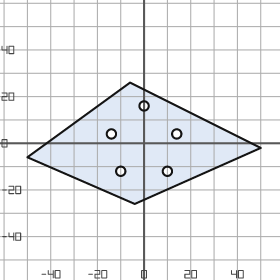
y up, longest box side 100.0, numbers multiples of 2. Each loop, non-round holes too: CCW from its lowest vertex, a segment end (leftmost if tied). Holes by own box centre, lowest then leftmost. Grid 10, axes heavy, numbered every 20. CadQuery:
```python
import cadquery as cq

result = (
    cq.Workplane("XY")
    .moveTo(-4.0, -26.0)
    .lineTo(50.0, -2.0)
    .lineTo(-6.0, 26.0)
    .lineTo(-50.0, -6.0)
    .close()
    .moveTo(-10.0, -12.0)
    .circle(2.0)
    .moveTo(10.0, -12.0)
    .circle(2.0)
    .moveTo(-14.0, 4.0)
    .circle(2.0)
    .moveTo(14.0, 4.0)
    .circle(2.0)
    .moveTo(0.0, 16.0)
    .circle(2.0)
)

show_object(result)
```